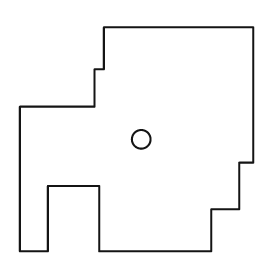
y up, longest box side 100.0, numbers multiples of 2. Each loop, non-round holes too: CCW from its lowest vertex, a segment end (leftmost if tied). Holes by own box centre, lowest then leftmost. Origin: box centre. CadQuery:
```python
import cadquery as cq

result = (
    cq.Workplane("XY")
    .moveTo(-50.0, -48.0)
    .lineTo(-38.0, -48.0)
    .lineTo(-38.0, -20.0)
    .lineTo(-16.0, -20.0)
    .lineTo(-16.0, -48.0)
    .lineTo(32.0, -48.0)
    .lineTo(32.0, -30.0)
    .lineTo(44.0, -30.0)
    .lineTo(44.0, -10.0)
    .lineTo(50.0, -10.0)
    .lineTo(50.0, 48.0)
    .lineTo(-14.0, 48.0)
    .lineTo(-14.0, 30.0)
    .lineTo(-18.0, 30.0)
    .lineTo(-18.0, 14.0)
    .lineTo(-50.0, 14.0)
    .close()
    .moveTo(2.0, 0.0)
    .circle(4.0)
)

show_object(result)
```